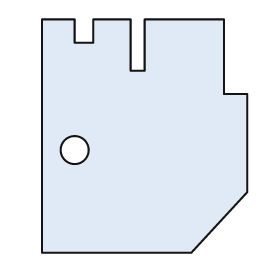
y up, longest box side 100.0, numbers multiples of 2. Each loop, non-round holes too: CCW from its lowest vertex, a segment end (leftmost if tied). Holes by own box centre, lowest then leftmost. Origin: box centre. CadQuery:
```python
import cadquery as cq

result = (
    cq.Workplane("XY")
    .moveTo(-44.0, -50.0)
    .lineTo(20.0, -50.0)
    .lineTo(44.0, -24.0)
    .lineTo(44.0, 18.0)
    .lineTo(34.0, 18.0)
    .lineTo(34.0, 50.0)
    .lineTo(0.0, 50.0)
    .lineTo(0.0, 28.0)
    .lineTo(-6.0, 28.0)
    .lineTo(-6.0, 50.0)
    .lineTo(-22.0, 50.0)
    .lineTo(-22.0, 40.0)
    .lineTo(-30.0, 40.0)
    .lineTo(-30.0, 50.0)
    .lineTo(-44.0, 50.0)
    .close()
    .moveTo(-30.0, -6.0)
    .circle(6.0)
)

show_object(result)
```